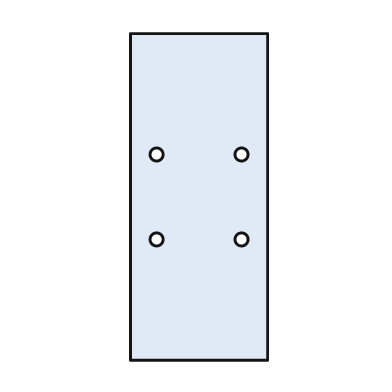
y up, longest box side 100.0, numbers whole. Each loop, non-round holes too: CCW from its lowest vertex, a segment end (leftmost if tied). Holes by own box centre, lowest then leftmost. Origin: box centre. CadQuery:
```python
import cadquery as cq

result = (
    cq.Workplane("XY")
    .moveTo(-21.0, -50.0)
    .lineTo(21.0, -50.0)
    .lineTo(21.0, 50.0)
    .lineTo(-21.0, 50.0)
    .close()
    .moveTo(-13.0, -13.0)
    .circle(2.0)
    .moveTo(13.0, -13.0)
    .circle(2.0)
    .moveTo(-13.0, 13.0)
    .circle(2.0)
    .moveTo(13.0, 13.0)
    .circle(2.0)
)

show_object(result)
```